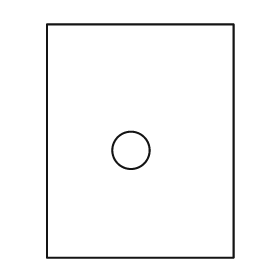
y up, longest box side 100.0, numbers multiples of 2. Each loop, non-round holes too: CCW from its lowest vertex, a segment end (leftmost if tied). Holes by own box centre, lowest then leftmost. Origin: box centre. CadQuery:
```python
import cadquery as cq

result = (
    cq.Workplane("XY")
    .moveTo(-40.0, -50.0)
    .lineTo(40.0, -50.0)
    .lineTo(40.0, 50.0)
    .lineTo(-40.0, 50.0)
    .close()
    .moveTo(-4.0, -4.0)
    .circle(8.0)
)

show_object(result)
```